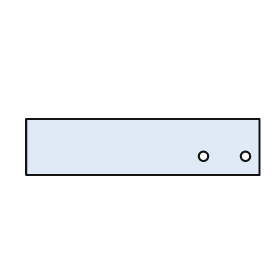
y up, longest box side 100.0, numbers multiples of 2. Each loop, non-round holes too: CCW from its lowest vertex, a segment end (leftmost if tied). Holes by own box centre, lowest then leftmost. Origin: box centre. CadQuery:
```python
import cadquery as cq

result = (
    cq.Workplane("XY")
    .moveTo(-50.0, -12.0)
    .lineTo(50.0, -12.0)
    .lineTo(50.0, 12.0)
    .lineTo(-50.0, 12.0)
    .close()
    .moveTo(26.0, -4.0)
    .circle(2.0)
    .moveTo(44.0, -4.0)
    .circle(2.0)
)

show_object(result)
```